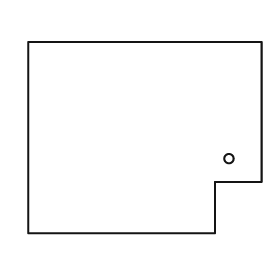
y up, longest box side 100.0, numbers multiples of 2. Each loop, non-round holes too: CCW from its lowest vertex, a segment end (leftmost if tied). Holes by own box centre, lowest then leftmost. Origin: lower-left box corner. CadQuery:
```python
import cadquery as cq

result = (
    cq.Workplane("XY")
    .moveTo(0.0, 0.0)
    .lineTo(80.0, 0.0)
    .lineTo(80.0, 22.0)
    .lineTo(100.0, 22.0)
    .lineTo(100.0, 82.0)
    .lineTo(0.0, 82.0)
    .close()
    .moveTo(86.0, 32.0)
    .circle(2.0)
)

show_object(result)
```